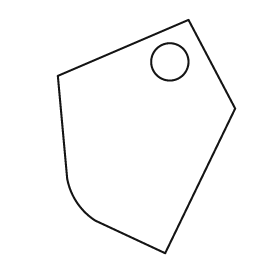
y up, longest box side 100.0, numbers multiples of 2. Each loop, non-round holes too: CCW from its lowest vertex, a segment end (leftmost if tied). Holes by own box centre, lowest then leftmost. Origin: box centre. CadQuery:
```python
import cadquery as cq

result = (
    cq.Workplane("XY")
    .moveTo(8.0, -50.0)
    .lineTo(38.0, 12.0)
    .lineTo(18.0, 50.0)
    .lineTo(-38.0, 26.0)
    .lineTo(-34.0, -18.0)
    .threePointArc((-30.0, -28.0), (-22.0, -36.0))
    .close()
    .moveTo(10.0, 32.0)
    .circle(8.0)
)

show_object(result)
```